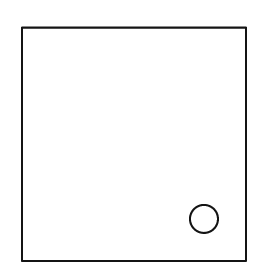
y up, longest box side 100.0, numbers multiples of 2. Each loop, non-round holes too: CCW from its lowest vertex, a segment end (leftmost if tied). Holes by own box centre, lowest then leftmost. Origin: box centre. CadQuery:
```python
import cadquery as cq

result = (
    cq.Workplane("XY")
    .moveTo(-48.0, -50.0)
    .lineTo(48.0, -50.0)
    .lineTo(48.0, 50.0)
    .lineTo(-48.0, 50.0)
    .close()
    .moveTo(30.0, -32.0)
    .circle(6.0)
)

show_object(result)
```